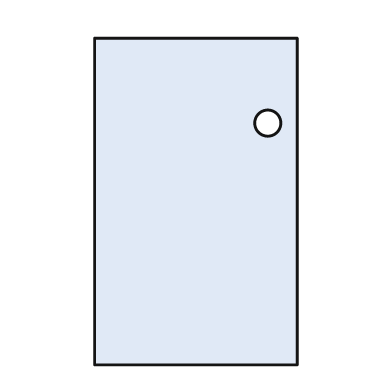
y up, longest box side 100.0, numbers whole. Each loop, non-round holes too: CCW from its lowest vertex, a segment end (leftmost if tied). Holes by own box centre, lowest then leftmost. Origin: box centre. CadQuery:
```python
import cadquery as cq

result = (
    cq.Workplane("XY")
    .moveTo(-31.0, -50.0)
    .lineTo(31.0, -50.0)
    .lineTo(31.0, 50.0)
    .lineTo(-31.0, 50.0)
    .close()
    .moveTo(22.0, 24.0)
    .circle(4.0)
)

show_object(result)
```